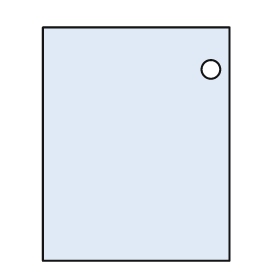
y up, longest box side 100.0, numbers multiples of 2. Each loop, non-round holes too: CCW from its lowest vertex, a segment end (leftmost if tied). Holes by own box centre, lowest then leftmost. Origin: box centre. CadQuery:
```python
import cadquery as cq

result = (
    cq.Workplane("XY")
    .moveTo(-40.0, -50.0)
    .lineTo(40.0, -50.0)
    .lineTo(40.0, 50.0)
    .lineTo(-40.0, 50.0)
    .close()
    .moveTo(32.0, 32.0)
    .circle(4.0)
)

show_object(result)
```